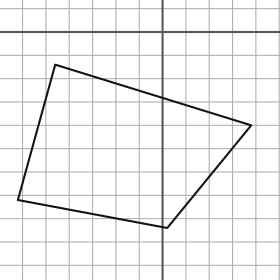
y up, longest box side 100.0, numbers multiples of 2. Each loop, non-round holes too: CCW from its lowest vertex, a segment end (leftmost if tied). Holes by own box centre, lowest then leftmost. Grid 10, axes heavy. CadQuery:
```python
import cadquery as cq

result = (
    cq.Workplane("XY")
    .moveTo(2.0, -84.0)
    .lineTo(38.0, -40.0)
    .lineTo(-46.0, -14.0)
    .lineTo(-62.0, -72.0)
    .close()
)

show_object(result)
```